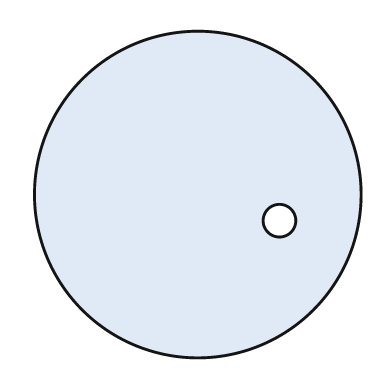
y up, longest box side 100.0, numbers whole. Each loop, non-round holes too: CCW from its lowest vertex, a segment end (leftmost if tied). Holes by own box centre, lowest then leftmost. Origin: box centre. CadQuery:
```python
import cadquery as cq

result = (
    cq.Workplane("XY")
    .moveTo(0.0, 0.0)
    .circle(50.0)
    .moveTo(25.0, -8.0)
    .circle(5.0)
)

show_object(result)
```